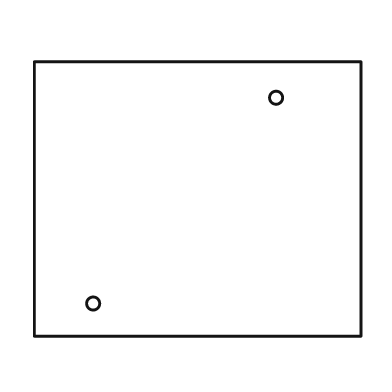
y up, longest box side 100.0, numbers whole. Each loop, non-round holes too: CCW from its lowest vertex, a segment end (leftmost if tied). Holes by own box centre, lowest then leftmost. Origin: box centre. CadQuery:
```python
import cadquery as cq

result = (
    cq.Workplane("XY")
    .moveTo(-50.0, -42.0)
    .lineTo(50.0, -42.0)
    .lineTo(50.0, 42.0)
    .lineTo(-50.0, 42.0)
    .close()
    .moveTo(-32.0, -32.0)
    .circle(2.0)
    .moveTo(24.0, 31.0)
    .circle(2.0)
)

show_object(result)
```